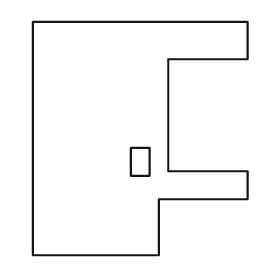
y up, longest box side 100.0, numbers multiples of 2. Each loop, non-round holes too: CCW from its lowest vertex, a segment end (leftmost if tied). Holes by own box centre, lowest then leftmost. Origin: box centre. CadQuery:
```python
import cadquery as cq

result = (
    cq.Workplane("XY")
    .moveTo(-46.0, -50.0)
    .lineTo(8.0, -50.0)
    .lineTo(8.0, -26.0)
    .lineTo(46.0, -26.0)
    .lineTo(46.0, -14.0)
    .lineTo(12.0, -14.0)
    .lineTo(12.0, 34.0)
    .lineTo(46.0, 34.0)
    .lineTo(46.0, 50.0)
    .lineTo(-46.0, 50.0)
    .close()
    .moveTo(-4.0, -16.0)
    .lineTo(4.0, -16.0)
    .lineTo(4.0, -4.0)
    .lineTo(-4.0, -4.0)
    .close()
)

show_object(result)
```